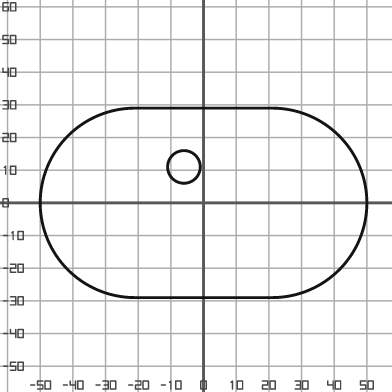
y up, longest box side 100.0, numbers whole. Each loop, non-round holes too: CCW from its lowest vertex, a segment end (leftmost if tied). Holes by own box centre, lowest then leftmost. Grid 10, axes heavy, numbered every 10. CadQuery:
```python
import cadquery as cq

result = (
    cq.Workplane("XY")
    .moveTo(-21.0, -29.0)
    .lineTo(21.0, -29.0)
    .threePointArc((50.0, 0.0), (21.0, 29.0))
    .lineTo(-21.0, 29.0)
    .threePointArc((-50.0, 0.0), (-21.0, -29.0))
    .close()
    .moveTo(-6.0, 11.0)
    .circle(5.0)
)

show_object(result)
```